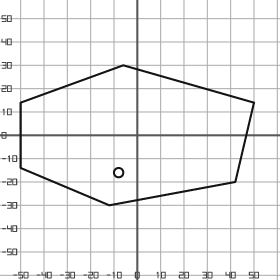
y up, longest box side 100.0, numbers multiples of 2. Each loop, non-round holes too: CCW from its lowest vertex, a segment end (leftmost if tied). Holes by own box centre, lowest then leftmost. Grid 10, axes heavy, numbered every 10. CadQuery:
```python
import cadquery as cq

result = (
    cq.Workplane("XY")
    .moveTo(-12.0, -30.0)
    .lineTo(42.0, -20.0)
    .lineTo(50.0, 14.0)
    .lineTo(-6.0, 30.0)
    .lineTo(-50.0, 14.0)
    .lineTo(-50.0, -14.0)
    .close()
    .moveTo(-8.0, -16.0)
    .circle(2.0)
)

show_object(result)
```